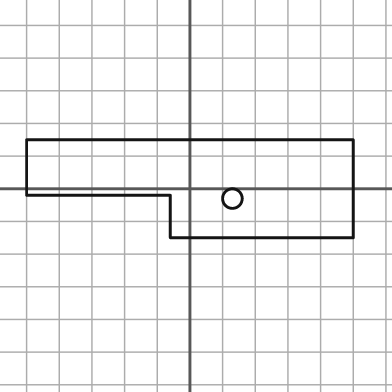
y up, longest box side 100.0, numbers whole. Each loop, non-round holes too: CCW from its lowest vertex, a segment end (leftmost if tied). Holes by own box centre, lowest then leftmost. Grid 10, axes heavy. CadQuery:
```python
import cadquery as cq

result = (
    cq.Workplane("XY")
    .moveTo(-6.0, -15.0)
    .lineTo(50.0, -15.0)
    .lineTo(50.0, 15.0)
    .lineTo(-50.0, 15.0)
    .lineTo(-50.0, -2.0)
    .lineTo(-6.0, -2.0)
    .close()
    .moveTo(13.0, -3.0)
    .circle(3.0)
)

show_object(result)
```